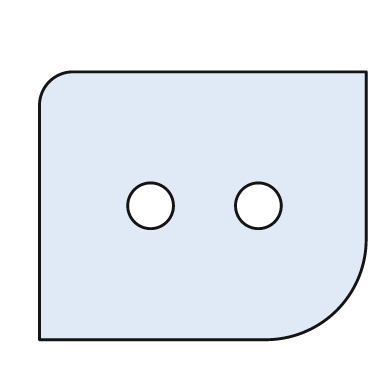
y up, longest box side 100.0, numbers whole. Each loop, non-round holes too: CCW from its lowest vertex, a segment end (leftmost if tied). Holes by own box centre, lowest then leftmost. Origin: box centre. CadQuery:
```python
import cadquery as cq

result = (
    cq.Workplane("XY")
    .moveTo(-50.0, -41.0)
    .lineTo(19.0, -41.0)
    .threePointArc((41.0, -32.0), (50.0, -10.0))
    .lineTo(50.0, 41.0)
    .lineTo(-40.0, 41.0)
    .threePointArc((-47.0, 38.0), (-50.0, 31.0))
    .close()
    .moveTo(-16.0, 0.0)
    .circle(7.0)
    .moveTo(17.0, 0.0)
    .circle(7.0)
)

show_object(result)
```